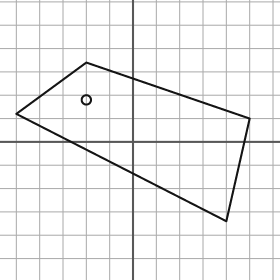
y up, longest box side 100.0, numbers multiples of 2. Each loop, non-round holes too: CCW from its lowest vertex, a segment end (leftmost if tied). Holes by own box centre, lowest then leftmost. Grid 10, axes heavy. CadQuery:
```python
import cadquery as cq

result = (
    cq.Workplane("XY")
    .moveTo(40.0, -34.0)
    .lineTo(50.0, 10.0)
    .lineTo(-20.0, 34.0)
    .lineTo(-50.0, 12.0)
    .close()
    .moveTo(-20.0, 18.0)
    .circle(2.0)
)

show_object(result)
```